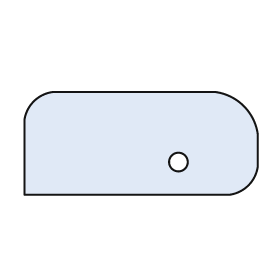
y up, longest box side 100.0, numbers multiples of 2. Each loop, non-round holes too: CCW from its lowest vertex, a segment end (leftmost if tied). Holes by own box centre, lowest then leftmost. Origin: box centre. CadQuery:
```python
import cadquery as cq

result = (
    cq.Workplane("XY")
    .moveTo(-50.0, -22.0)
    .lineTo(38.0, -22.0)
    .threePointArc((46.0, -18.0), (50.0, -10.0))
    .lineTo(50.0, 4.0)
    .threePointArc((44.0, 16.0), (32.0, 22.0))
    .lineTo(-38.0, 22.0)
    .threePointArc((-46.0, 18.0), (-50.0, 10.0))
    .close()
    .moveTo(16.0, -8.0)
    .circle(4.0)
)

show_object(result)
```